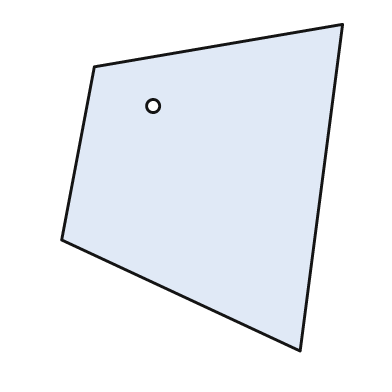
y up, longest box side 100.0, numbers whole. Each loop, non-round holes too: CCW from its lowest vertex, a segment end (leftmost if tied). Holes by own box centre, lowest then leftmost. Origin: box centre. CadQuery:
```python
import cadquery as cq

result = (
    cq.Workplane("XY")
    .moveTo(30.0, -50.0)
    .lineTo(43.0, 50.0)
    .lineTo(-33.0, 37.0)
    .lineTo(-43.0, -16.0)
    .close()
    .moveTo(-15.0, 25.0)
    .circle(2.0)
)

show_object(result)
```